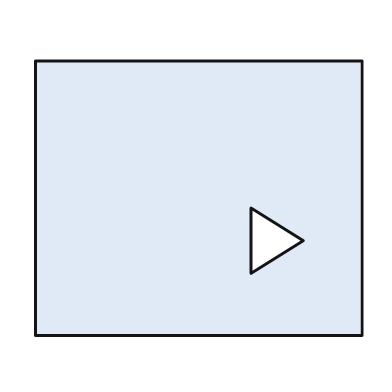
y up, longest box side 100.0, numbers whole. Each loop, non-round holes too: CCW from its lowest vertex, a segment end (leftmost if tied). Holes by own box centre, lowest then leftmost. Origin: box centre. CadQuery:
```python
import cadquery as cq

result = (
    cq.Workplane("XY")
    .moveTo(-50.0, -42.0)
    .lineTo(50.0, -42.0)
    .lineTo(50.0, 42.0)
    .lineTo(-50.0, 42.0)
    .close()
    .moveTo(16.0, -23.0)
    .lineTo(32.0, -13.0)
    .lineTo(16.0, -3.0)
    .close()
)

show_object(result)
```